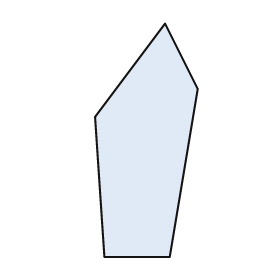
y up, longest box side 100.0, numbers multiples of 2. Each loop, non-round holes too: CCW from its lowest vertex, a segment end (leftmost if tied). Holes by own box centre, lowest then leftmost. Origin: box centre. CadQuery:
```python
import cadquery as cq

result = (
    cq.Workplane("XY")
    .moveTo(-18.0, -50.0)
    .lineTo(10.0, -50.0)
    .lineTo(22.0, 22.0)
    .lineTo(8.0, 50.0)
    .lineTo(-22.0, 10.0)
    .close()
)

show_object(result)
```